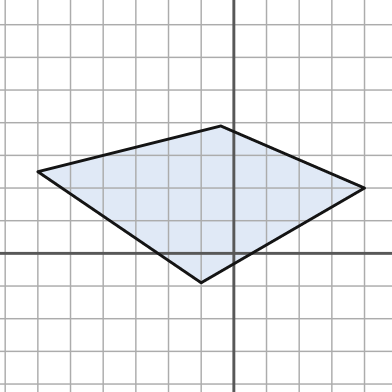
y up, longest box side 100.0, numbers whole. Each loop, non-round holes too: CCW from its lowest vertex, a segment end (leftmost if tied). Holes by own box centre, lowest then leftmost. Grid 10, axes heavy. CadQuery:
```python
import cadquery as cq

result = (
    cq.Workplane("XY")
    .moveTo(-10.0, -9.0)
    .lineTo(40.0, 20.0)
    .lineTo(-4.0, 39.0)
    .lineTo(-60.0, 25.0)
    .close()
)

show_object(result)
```